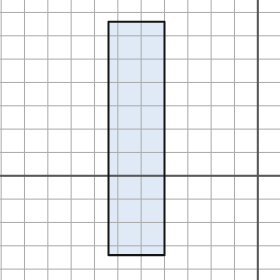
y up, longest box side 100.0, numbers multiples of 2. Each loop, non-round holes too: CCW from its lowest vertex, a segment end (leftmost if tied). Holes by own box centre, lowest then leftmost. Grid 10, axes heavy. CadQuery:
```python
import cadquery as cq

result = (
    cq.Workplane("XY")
    .moveTo(-64.0, -34.0)
    .lineTo(-40.0, -34.0)
    .lineTo(-40.0, 66.0)
    .lineTo(-64.0, 66.0)
    .close()
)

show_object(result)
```